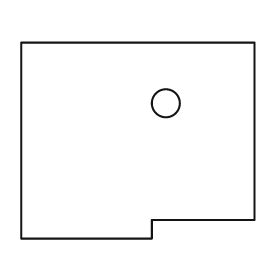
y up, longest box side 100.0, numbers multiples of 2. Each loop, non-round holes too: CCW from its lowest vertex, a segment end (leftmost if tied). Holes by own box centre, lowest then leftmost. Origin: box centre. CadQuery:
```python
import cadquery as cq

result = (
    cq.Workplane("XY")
    .moveTo(-50.0, -42.0)
    .lineTo(6.0, -42.0)
    .lineTo(6.0, -34.0)
    .lineTo(50.0, -34.0)
    .lineTo(50.0, 42.0)
    .lineTo(-50.0, 42.0)
    .close()
    .moveTo(12.0, 16.0)
    .circle(6.0)
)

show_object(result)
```